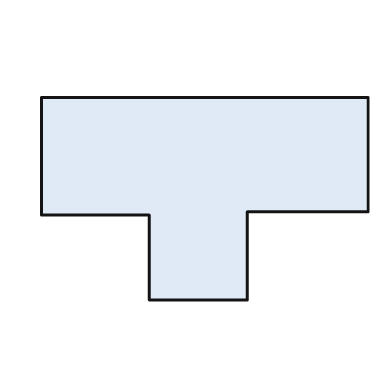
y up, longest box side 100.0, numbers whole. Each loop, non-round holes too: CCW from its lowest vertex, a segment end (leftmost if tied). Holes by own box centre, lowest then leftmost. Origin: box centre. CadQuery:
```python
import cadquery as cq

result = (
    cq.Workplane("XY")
    .moveTo(-17.0, -31.0)
    .lineTo(13.0, -31.0)
    .lineTo(13.0, -4.0)
    .lineTo(50.0, -4.0)
    .lineTo(50.0, 31.0)
    .lineTo(-50.0, 31.0)
    .lineTo(-50.0, -5.0)
    .lineTo(-17.0, -5.0)
    .close()
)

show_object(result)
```